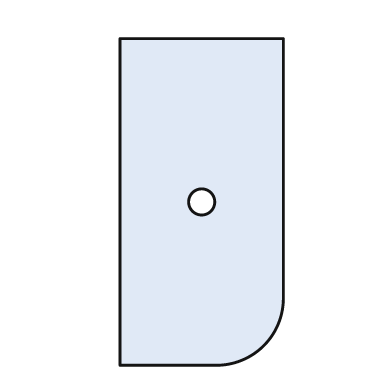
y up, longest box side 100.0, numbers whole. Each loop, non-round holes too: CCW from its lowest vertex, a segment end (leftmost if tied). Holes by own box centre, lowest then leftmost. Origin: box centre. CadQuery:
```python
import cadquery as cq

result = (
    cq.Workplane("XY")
    .moveTo(-25.0, -50.0)
    .lineTo(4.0, -50.0)
    .threePointArc((19.0, -44.0), (25.0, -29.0))
    .lineTo(25.0, 50.0)
    .lineTo(-25.0, 50.0)
    .close()
    .moveTo(0.0, 0.0)
    .circle(4.0)
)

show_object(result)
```